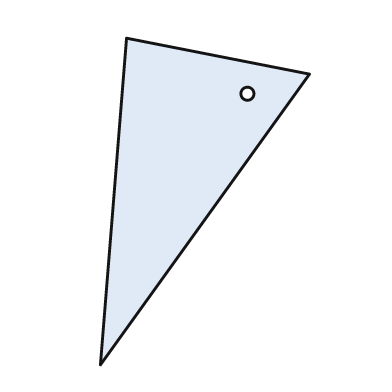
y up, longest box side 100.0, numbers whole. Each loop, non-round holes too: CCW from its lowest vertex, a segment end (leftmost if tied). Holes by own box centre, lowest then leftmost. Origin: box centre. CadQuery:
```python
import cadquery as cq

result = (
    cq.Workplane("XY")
    .moveTo(-32.0, -50.0)
    .lineTo(32.0, 39.0)
    .lineTo(-24.0, 50.0)
    .close()
    .moveTo(13.0, 33.0)
    .circle(2.0)
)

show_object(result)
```